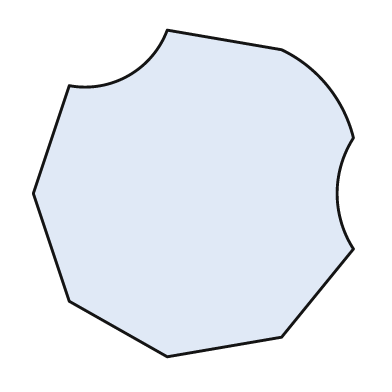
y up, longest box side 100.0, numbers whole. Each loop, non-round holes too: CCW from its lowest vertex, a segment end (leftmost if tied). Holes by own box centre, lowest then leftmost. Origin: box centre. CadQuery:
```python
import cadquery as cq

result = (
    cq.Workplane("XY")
    .moveTo(-8.0, -50.0)
    .lineTo(27.0, -44.0)
    .lineTo(49.0, -17.0)
    .threePointArc((44.0, 0.0), (49.0, 17.0))
    .threePointArc((41.0, 33.0), (27.0, 44.0))
    .lineTo(-8.0, 50.0)
    .threePointArc((-20.0, 36.0), (-38.0, 33.0))
    .lineTo(-49.0, 0.0)
    .lineTo(-38.0, -33.0)
    .close()
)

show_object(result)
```